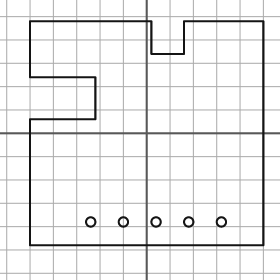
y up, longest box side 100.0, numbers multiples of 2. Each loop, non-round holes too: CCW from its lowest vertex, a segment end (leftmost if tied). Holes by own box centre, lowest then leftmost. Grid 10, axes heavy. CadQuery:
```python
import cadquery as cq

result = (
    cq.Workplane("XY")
    .moveTo(-50.0, -48.0)
    .lineTo(50.0, -48.0)
    .lineTo(50.0, 48.0)
    .lineTo(16.0, 48.0)
    .lineTo(16.0, 34.0)
    .lineTo(2.0, 34.0)
    .lineTo(2.0, 48.0)
    .lineTo(-50.0, 48.0)
    .lineTo(-50.0, 24.0)
    .lineTo(-22.0, 24.0)
    .lineTo(-22.0, 6.0)
    .lineTo(-50.0, 6.0)
    .close()
    .moveTo(-24.0, -38.0)
    .circle(2.0)
    .moveTo(-10.0, -38.0)
    .circle(2.0)
    .moveTo(4.0, -38.0)
    .circle(2.0)
    .moveTo(18.0, -38.0)
    .circle(2.0)
    .moveTo(32.0, -38.0)
    .circle(2.0)
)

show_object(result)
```